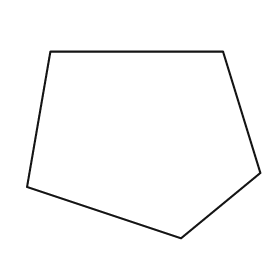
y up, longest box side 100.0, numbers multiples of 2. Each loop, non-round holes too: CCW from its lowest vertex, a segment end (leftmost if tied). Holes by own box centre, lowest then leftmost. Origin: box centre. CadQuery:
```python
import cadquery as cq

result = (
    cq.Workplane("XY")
    .moveTo(16.0, -40.0)
    .lineTo(50.0, -12.0)
    .lineTo(34.0, 40.0)
    .lineTo(-40.0, 40.0)
    .lineTo(-50.0, -18.0)
    .close()
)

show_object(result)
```